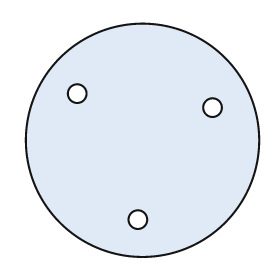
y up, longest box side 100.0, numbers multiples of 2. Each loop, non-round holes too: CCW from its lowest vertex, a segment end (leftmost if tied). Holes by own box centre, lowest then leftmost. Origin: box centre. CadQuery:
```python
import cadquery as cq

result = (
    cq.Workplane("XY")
    .moveTo(0.0, 0.0)
    .circle(50.0)
    .moveTo(-2.0, -34.0)
    .circle(4.0)
    .moveTo(30.0, 14.0)
    .circle(4.0)
    .moveTo(-28.0, 20.0)
    .circle(4.0)
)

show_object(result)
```